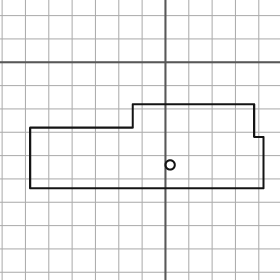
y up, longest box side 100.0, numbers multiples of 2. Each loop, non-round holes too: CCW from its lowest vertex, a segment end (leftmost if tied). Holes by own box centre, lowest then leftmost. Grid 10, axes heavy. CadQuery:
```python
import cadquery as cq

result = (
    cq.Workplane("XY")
    .moveTo(-58.0, -54.0)
    .lineTo(42.0, -54.0)
    .lineTo(42.0, -32.0)
    .lineTo(38.0, -32.0)
    .lineTo(38.0, -18.0)
    .lineTo(-14.0, -18.0)
    .lineTo(-14.0, -28.0)
    .lineTo(-58.0, -28.0)
    .close()
    .moveTo(2.0, -44.0)
    .circle(2.0)
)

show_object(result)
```